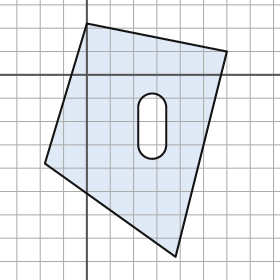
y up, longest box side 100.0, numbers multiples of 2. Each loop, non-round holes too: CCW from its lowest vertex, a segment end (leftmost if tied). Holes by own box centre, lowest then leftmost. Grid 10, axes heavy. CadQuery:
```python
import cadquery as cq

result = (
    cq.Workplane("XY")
    .moveTo(38.0, -78.0)
    .lineTo(60.0, 10.0)
    .lineTo(0.0, 22.0)
    .lineTo(-18.0, -38.0)
    .close()
    .moveTo(22.0, -30.0)
    .threePointArc((28.0, -36.0), (34.0, -30.0))
    .lineTo(34.0, -14.0)
    .threePointArc((28.0, -8.0), (22.0, -14.0))
    .close()
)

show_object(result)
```